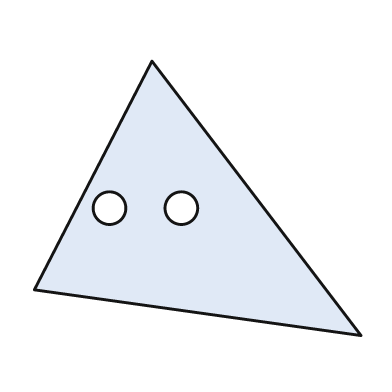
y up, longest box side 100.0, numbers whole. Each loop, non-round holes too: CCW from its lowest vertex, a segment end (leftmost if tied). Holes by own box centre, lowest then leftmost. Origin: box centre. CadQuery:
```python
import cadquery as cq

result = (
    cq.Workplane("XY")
    .moveTo(50.0, -42.0)
    .lineTo(-14.0, 42.0)
    .lineTo(-50.0, -28.0)
    .close()
    .moveTo(-27.0, -3.0)
    .circle(5.0)
    .moveTo(-5.0, -3.0)
    .circle(5.0)
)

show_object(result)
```